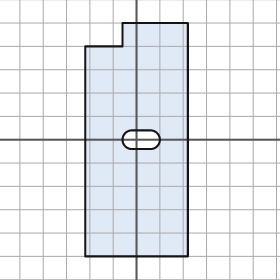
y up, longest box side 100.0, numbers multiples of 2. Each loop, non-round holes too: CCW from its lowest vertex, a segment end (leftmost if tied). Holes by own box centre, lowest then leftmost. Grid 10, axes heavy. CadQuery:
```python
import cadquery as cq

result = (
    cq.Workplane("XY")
    .moveTo(-22.0, -50.0)
    .lineTo(22.0, -50.0)
    .lineTo(22.0, 50.0)
    .lineTo(-6.0, 50.0)
    .lineTo(-6.0, 40.0)
    .lineTo(-22.0, 40.0)
    .close()
    .moveTo(-2.0, -4.0)
    .lineTo(6.0, -4.0)
    .threePointArc((10.0, 0.0), (6.0, 4.0))
    .lineTo(-2.0, 4.0)
    .threePointArc((-6.0, 0.0), (-2.0, -4.0))
    .close()
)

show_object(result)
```